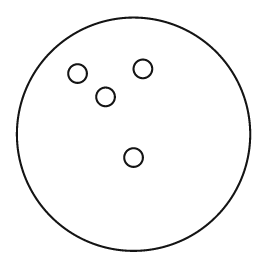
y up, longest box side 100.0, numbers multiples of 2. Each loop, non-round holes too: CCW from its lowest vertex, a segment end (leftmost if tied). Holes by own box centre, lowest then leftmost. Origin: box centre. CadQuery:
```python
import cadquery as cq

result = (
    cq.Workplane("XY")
    .moveTo(0.0, 0.0)
    .circle(50.0)
    .moveTo(0.0, -10.0)
    .circle(4.0)
    .moveTo(-12.0, 16.0)
    .circle(4.0)
    .moveTo(-24.0, 26.0)
    .circle(4.0)
    .moveTo(4.0, 28.0)
    .circle(4.0)
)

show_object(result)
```